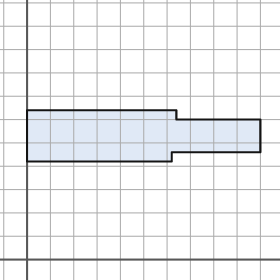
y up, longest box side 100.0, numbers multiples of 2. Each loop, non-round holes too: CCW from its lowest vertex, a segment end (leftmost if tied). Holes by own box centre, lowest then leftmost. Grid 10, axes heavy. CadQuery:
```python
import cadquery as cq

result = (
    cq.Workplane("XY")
    .moveTo(0.0, 42.0)
    .lineTo(62.0, 42.0)
    .lineTo(62.0, 46.0)
    .lineTo(100.0, 46.0)
    .lineTo(100.0, 60.0)
    .lineTo(64.0, 60.0)
    .lineTo(64.0, 64.0)
    .lineTo(0.0, 64.0)
    .close()
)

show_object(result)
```